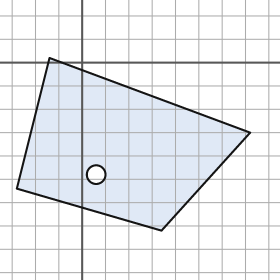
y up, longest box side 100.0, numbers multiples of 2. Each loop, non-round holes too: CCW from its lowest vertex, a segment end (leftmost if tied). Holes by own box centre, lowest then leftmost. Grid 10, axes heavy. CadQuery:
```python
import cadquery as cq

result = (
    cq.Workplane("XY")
    .moveTo(34.0, -72.0)
    .lineTo(72.0, -30.0)
    .lineTo(-14.0, 2.0)
    .lineTo(-28.0, -54.0)
    .close()
    .moveTo(6.0, -48.0)
    .circle(4.0)
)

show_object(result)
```